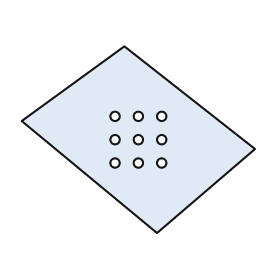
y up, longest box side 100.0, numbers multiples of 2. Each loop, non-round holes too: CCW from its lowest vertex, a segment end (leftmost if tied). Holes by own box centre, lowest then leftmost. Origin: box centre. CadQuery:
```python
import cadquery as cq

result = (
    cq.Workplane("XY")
    .moveTo(8.0, -40.0)
    .lineTo(50.0, -4.0)
    .lineTo(-6.0, 40.0)
    .lineTo(-50.0, 8.0)
    .close()
    .moveTo(-10.0, -10.0)
    .circle(2.0)
    .moveTo(0.0, -10.0)
    .circle(2.0)
    .moveTo(10.0, -10.0)
    .circle(2.0)
    .moveTo(-10.0, 0.0)
    .circle(2.0)
    .moveTo(0.0, 0.0)
    .circle(2.0)
    .moveTo(10.0, 0.0)
    .circle(2.0)
    .moveTo(-10.0, 10.0)
    .circle(2.0)
    .moveTo(0.0, 10.0)
    .circle(2.0)
    .moveTo(10.0, 10.0)
    .circle(2.0)
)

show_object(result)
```